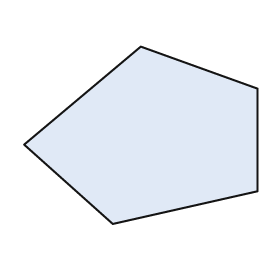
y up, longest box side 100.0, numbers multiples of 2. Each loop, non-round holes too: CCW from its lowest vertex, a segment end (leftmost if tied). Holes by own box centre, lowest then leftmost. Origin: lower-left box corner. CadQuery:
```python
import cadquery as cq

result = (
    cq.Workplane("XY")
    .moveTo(38.0, 0.0)
    .lineTo(100.0, 14.0)
    .lineTo(100.0, 58.0)
    .lineTo(50.0, 76.0)
    .lineTo(0.0, 34.0)
    .close()
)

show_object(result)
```